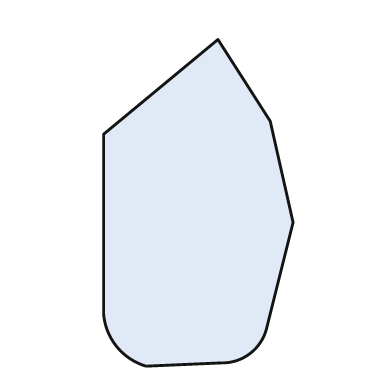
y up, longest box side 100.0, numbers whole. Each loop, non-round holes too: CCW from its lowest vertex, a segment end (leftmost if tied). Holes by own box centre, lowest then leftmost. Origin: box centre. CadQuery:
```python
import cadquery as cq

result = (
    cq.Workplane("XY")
    .moveTo(-16.0, -50.0)
    .lineTo(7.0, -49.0)
    .threePointArc((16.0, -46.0), (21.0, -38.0))
    .lineTo(29.0, -6.0)
    .lineTo(22.0, 25.0)
    .lineTo(6.0, 50.0)
    .lineTo(-29.0, 21.0)
    .lineTo(-29.0, -34.0)
    .threePointArc((-25.0, -44.0), (-16.0, -50.0))
    .close()
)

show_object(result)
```